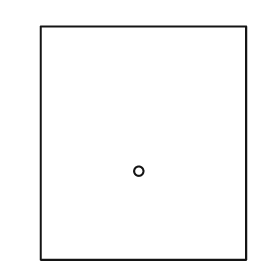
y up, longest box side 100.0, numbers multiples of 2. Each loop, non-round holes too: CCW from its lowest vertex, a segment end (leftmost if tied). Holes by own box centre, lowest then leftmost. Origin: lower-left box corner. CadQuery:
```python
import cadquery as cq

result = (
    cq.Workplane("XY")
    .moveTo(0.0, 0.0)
    .lineTo(88.0, 0.0)
    .lineTo(88.0, 100.0)
    .lineTo(0.0, 100.0)
    .close()
    .moveTo(42.0, 38.0)
    .circle(2.0)
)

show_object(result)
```